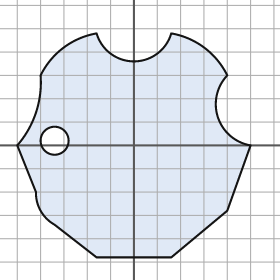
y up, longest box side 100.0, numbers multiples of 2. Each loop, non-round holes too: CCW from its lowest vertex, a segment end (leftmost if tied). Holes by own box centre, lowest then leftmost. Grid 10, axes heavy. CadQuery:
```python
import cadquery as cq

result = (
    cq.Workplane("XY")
    .moveTo(-16.0, -48.0)
    .lineTo(16.0, -48.0)
    .lineTo(40.0, -28.0)
    .lineTo(50.0, 0.0)
    .threePointArc((36.0, 12.0), (40.0, 30.0))
    .threePointArc((30.0, 42.0), (16.0, 48.0))
    .threePointArc((0.0, 36.0), (-16.0, 48.0))
    .threePointArc((-30.0, 42.0), (-40.0, 30.0))
    .threePointArc((-42.0, 14.0), (-50.0, 0.0))
    .lineTo(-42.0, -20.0)
    .threePointArc((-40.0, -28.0), (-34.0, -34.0))
    .close()
    .moveTo(-34.0, 2.0)
    .circle(6.0)
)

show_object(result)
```